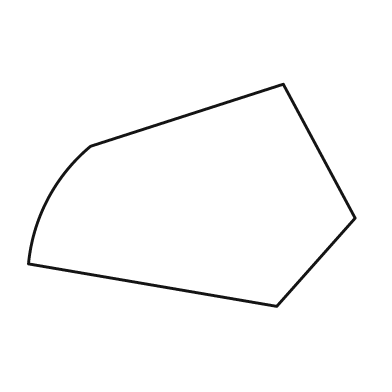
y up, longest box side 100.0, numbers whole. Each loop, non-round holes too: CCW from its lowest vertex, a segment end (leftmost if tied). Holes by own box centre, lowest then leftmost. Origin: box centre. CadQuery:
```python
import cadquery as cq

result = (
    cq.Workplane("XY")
    .moveTo(26.0, -34.0)
    .lineTo(50.0, -7.0)
    .lineTo(28.0, 34.0)
    .lineTo(-31.0, 15.0)
    .threePointArc((-44.0, -1.0), (-50.0, -21.0))
    .close()
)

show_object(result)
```